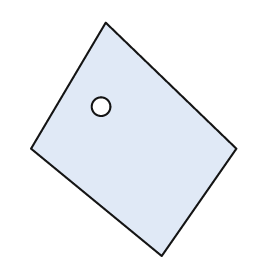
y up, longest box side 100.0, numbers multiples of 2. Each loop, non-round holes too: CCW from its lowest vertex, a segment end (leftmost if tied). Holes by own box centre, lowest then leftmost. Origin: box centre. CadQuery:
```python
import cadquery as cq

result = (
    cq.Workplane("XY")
    .moveTo(12.0, -50.0)
    .lineTo(44.0, -4.0)
    .lineTo(-12.0, 50.0)
    .lineTo(-44.0, -4.0)
    .close()
    .moveTo(-14.0, 14.0)
    .circle(4.0)
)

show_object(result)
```